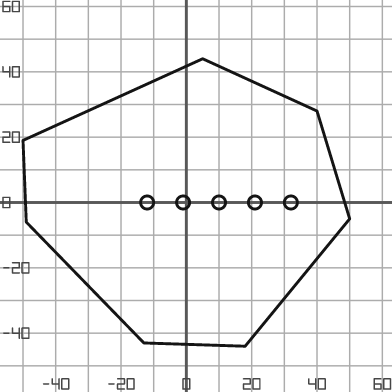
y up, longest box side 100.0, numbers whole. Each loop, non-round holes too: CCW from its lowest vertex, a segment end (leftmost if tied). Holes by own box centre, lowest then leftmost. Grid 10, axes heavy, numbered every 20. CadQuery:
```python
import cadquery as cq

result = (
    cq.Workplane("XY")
    .moveTo(18.0, -44.0)
    .lineTo(50.0, -5.0)
    .lineTo(40.0, 28.0)
    .lineTo(5.0, 44.0)
    .lineTo(-50.0, 19.0)
    .lineTo(-49.0, -6.0)
    .lineTo(-13.0, -43.0)
    .close()
    .moveTo(-12.0, 0.0)
    .circle(2.0)
    .moveTo(-1.0, 0.0)
    .circle(2.0)
    .moveTo(10.0, 0.0)
    .circle(2.0)
    .moveTo(21.0, 0.0)
    .circle(2.0)
    .moveTo(32.0, 0.0)
    .circle(2.0)
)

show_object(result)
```